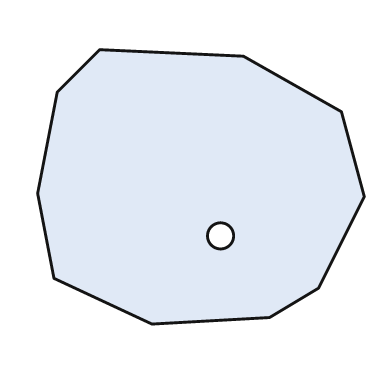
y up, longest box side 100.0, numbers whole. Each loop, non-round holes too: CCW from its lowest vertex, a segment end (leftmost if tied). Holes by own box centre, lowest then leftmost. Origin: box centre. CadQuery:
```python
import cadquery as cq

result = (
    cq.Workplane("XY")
    .moveTo(-15.0, -42.0)
    .lineTo(21.0, -40.0)
    .lineTo(36.0, -31.0)
    .lineTo(50.0, -3.0)
    .lineTo(43.0, 23.0)
    .lineTo(13.0, 40.0)
    .lineTo(-31.0, 42.0)
    .lineTo(-44.0, 29.0)
    .lineTo(-50.0, -2.0)
    .lineTo(-45.0, -28.0)
    .close()
    .moveTo(6.0, -15.0)
    .circle(4.0)
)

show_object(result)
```